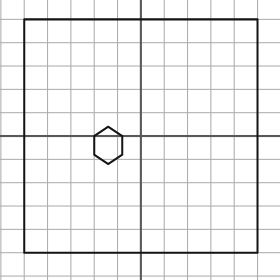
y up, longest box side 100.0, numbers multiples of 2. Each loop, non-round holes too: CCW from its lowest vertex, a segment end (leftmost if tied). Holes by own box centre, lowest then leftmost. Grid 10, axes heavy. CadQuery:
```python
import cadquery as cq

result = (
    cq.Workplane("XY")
    .moveTo(-50.0, -50.0)
    .lineTo(50.0, -50.0)
    .lineTo(50.0, 50.0)
    .lineTo(-50.0, 50.0)
    .close()
    .moveTo(-14.0, -12.0)
    .lineTo(-8.0, -8.0)
    .lineTo(-8.0, 0.0)
    .lineTo(-14.0, 4.0)
    .lineTo(-20.0, 0.0)
    .lineTo(-20.0, -8.0)
    .close()
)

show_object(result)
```